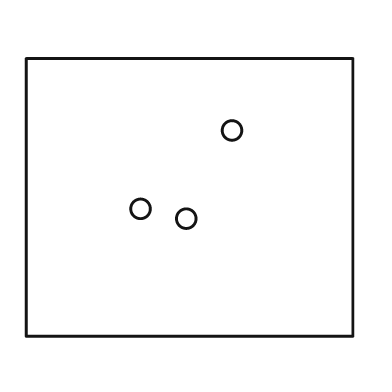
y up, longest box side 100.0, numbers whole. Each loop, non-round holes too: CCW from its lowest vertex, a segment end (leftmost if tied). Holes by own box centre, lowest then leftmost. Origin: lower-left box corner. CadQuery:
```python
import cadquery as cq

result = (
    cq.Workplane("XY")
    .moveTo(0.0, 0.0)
    .lineTo(100.0, 0.0)
    .lineTo(100.0, 85.0)
    .lineTo(0.0, 85.0)
    .close()
    .moveTo(49.0, 36.0)
    .circle(3.0)
    .moveTo(35.0, 39.0)
    .circle(3.0)
    .moveTo(63.0, 63.0)
    .circle(3.0)
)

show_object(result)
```